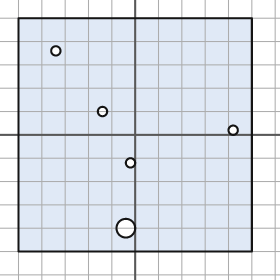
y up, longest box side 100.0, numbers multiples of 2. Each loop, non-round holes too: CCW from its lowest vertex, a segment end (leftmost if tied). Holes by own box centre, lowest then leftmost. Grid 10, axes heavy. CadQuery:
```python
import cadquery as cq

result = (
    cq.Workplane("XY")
    .moveTo(-50.0, -50.0)
    .lineTo(50.0, -50.0)
    .lineTo(50.0, 50.0)
    .lineTo(-50.0, 50.0)
    .close()
    .moveTo(-4.0, -40.0)
    .circle(4.0)
    .moveTo(-2.0, -12.0)
    .circle(2.0)
    .moveTo(42.0, 2.0)
    .circle(2.0)
    .moveTo(-14.0, 10.0)
    .circle(2.0)
    .moveTo(-34.0, 36.0)
    .circle(2.0)
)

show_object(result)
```